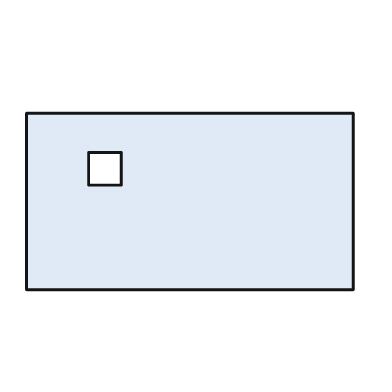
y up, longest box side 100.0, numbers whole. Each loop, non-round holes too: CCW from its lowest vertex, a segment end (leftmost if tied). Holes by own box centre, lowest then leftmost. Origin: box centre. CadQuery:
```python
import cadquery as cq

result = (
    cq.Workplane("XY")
    .moveTo(-50.0, -27.0)
    .lineTo(50.0, -27.0)
    .lineTo(50.0, 27.0)
    .lineTo(-50.0, 27.0)
    .close()
    .moveTo(-31.0, 5.0)
    .lineTo(-21.0, 5.0)
    .lineTo(-21.0, 15.0)
    .lineTo(-31.0, 15.0)
    .close()
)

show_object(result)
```